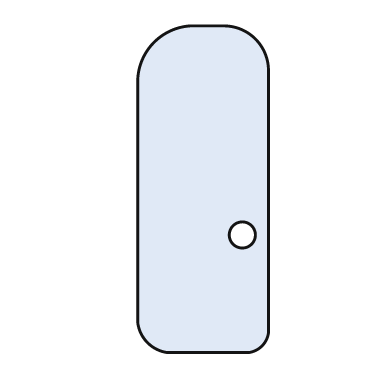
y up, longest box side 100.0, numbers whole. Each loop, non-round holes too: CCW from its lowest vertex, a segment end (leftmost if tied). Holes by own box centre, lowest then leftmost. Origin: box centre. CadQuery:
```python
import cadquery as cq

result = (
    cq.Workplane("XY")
    .moveTo(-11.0, -50.0)
    .lineTo(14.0, -50.0)
    .threePointArc((18.0, -48.0), (20.0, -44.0))
    .lineTo(20.0, 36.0)
    .threePointArc((16.0, 46.0), (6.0, 50.0))
    .lineTo(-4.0, 50.0)
    .threePointArc((-15.0, 45.0), (-20.0, 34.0))
    .lineTo(-20.0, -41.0)
    .threePointArc((-17.0, -47.0), (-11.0, -50.0))
    .close()
    .moveTo(12.0, -14.0)
    .circle(4.0)
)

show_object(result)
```